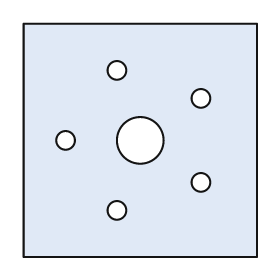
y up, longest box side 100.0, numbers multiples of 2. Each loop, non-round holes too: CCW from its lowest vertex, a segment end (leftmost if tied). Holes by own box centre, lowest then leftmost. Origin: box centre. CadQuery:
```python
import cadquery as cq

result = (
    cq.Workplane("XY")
    .moveTo(-50.0, -50.0)
    .lineTo(50.0, -50.0)
    .lineTo(50.0, 50.0)
    .lineTo(-50.0, 50.0)
    .close()
    .moveTo(-10.0, -30.0)
    .circle(4.0)
    .moveTo(26.0, -18.0)
    .circle(4.0)
    .moveTo(-32.0, 0.0)
    .circle(4.0)
    .moveTo(0.0, 0.0)
    .circle(10.0)
    .moveTo(26.0, 18.0)
    .circle(4.0)
    .moveTo(-10.0, 30.0)
    .circle(4.0)
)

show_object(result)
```